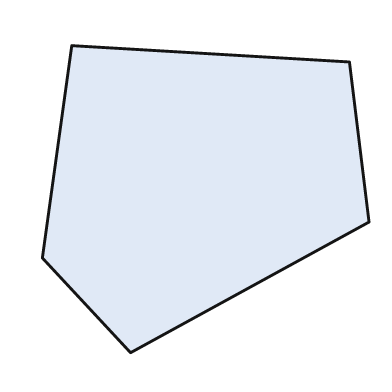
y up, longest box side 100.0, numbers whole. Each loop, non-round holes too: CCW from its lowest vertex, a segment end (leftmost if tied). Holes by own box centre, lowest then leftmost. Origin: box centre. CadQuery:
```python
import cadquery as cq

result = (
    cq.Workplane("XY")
    .moveTo(-23.0, -47.0)
    .lineTo(50.0, -7.0)
    .lineTo(44.0, 42.0)
    .lineTo(-41.0, 47.0)
    .lineTo(-50.0, -18.0)
    .close()
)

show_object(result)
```